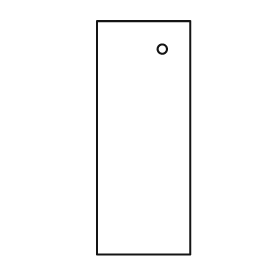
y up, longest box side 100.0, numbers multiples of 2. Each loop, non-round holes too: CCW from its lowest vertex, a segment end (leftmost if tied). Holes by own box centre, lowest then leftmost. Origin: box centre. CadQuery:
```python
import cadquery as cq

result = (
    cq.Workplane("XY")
    .moveTo(-20.0, -50.0)
    .lineTo(20.0, -50.0)
    .lineTo(20.0, 50.0)
    .lineTo(-20.0, 50.0)
    .close()
    .moveTo(8.0, 38.0)
    .circle(2.0)
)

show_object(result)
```